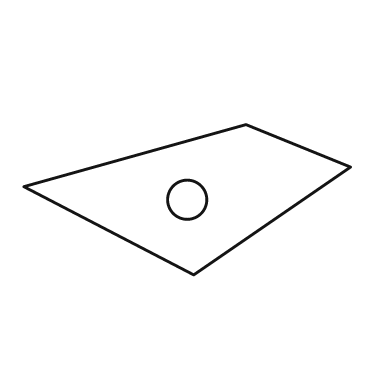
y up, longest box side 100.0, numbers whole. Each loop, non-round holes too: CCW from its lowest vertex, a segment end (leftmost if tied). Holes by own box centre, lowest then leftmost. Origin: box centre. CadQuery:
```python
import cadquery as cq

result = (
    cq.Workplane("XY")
    .moveTo(2.0, -23.0)
    .lineTo(50.0, 10.0)
    .lineTo(18.0, 23.0)
    .lineTo(-50.0, 4.0)
    .close()
    .moveTo(0.0, 0.0)
    .circle(6.0)
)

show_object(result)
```